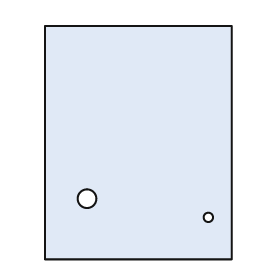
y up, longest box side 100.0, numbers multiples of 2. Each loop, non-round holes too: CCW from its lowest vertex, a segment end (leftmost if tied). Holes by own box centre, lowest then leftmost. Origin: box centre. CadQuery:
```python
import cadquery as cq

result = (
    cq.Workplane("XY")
    .moveTo(-40.0, -50.0)
    .lineTo(40.0, -50.0)
    .lineTo(40.0, 50.0)
    .lineTo(-40.0, 50.0)
    .close()
    .moveTo(30.0, -32.0)
    .circle(2.0)
    .moveTo(-22.0, -24.0)
    .circle(4.0)
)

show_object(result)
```